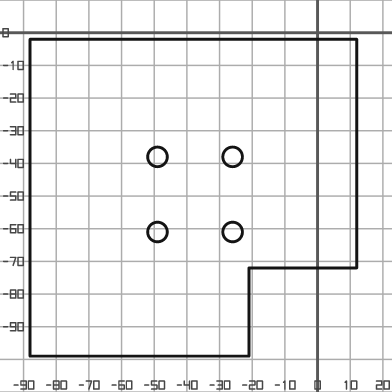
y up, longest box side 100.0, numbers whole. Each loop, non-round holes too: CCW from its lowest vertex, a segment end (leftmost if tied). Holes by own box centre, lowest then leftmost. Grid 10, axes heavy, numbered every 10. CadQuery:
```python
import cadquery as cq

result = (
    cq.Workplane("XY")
    .moveTo(-88.0, -99.0)
    .lineTo(-21.0, -99.0)
    .lineTo(-21.0, -72.0)
    .lineTo(12.0, -72.0)
    .lineTo(12.0, -2.0)
    .lineTo(-88.0, -2.0)
    .close()
    .moveTo(-49.0, -61.0)
    .circle(3.0)
    .moveTo(-26.0, -61.0)
    .circle(3.0)
    .moveTo(-49.0, -38.0)
    .circle(3.0)
    .moveTo(-26.0, -38.0)
    .circle(3.0)
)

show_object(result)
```